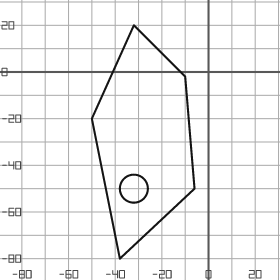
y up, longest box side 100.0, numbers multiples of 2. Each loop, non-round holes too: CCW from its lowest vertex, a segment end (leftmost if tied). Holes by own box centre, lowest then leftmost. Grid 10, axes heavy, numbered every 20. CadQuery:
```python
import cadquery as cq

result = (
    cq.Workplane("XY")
    .moveTo(-38.0, -80.0)
    .lineTo(-6.0, -50.0)
    .lineTo(-10.0, -2.0)
    .lineTo(-32.0, 20.0)
    .lineTo(-50.0, -20.0)
    .close()
    .moveTo(-32.0, -50.0)
    .circle(6.0)
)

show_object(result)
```